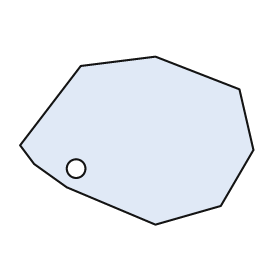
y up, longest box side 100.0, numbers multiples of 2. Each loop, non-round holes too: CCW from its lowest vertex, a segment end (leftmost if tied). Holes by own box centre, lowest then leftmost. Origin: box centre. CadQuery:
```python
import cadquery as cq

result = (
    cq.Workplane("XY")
    .moveTo(8.0, -36.0)
    .lineTo(36.0, -28.0)
    .lineTo(50.0, -4.0)
    .lineTo(44.0, 22.0)
    .lineTo(8.0, 36.0)
    .lineTo(-24.0, 32.0)
    .lineTo(-50.0, -2.0)
    .lineTo(-44.0, -10.0)
    .lineTo(-30.0, -20.0)
    .close()
    .moveTo(-26.0, -12.0)
    .circle(4.0)
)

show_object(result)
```